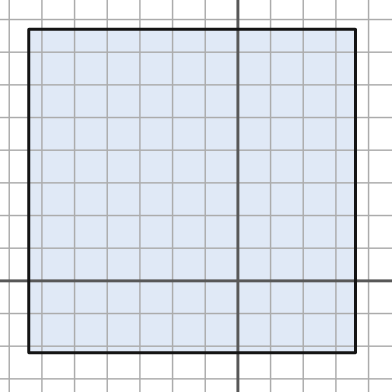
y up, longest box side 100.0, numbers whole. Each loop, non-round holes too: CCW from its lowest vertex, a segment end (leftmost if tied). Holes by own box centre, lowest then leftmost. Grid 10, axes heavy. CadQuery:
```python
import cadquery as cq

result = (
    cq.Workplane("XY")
    .moveTo(-64.0, -22.0)
    .lineTo(36.0, -22.0)
    .lineTo(36.0, 77.0)
    .lineTo(-64.0, 77.0)
    .close()
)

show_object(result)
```